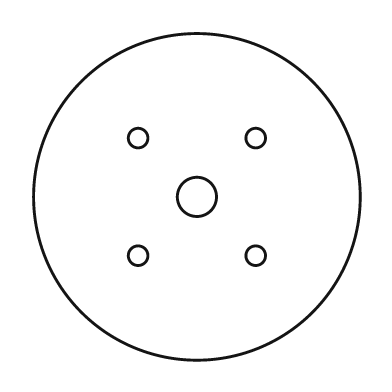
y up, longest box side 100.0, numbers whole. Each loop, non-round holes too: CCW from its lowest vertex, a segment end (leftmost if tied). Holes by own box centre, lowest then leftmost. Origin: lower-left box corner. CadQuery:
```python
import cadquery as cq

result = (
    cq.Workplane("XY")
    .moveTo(50.0, 50.0)
    .circle(50.0)
    .moveTo(32.0, 32.0)
    .circle(3.0)
    .moveTo(68.0, 32.0)
    .circle(3.0)
    .moveTo(50.0, 50.0)
    .circle(6.0)
    .moveTo(32.0, 68.0)
    .circle(3.0)
    .moveTo(68.0, 68.0)
    .circle(3.0)
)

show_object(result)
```